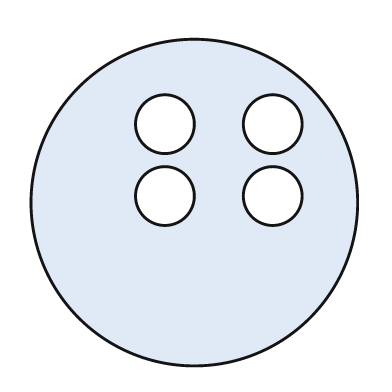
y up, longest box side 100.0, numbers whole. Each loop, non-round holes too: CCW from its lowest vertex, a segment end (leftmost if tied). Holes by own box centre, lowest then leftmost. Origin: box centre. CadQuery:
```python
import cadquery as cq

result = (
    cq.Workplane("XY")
    .moveTo(0.0, 0.0)
    .circle(50.0)
    .moveTo(-9.0, 2.0)
    .circle(9.0)
    .moveTo(24.0, 2.0)
    .circle(9.0)
    .moveTo(-9.0, 24.0)
    .circle(9.0)
    .moveTo(24.0, 24.0)
    .circle(9.0)
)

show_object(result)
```